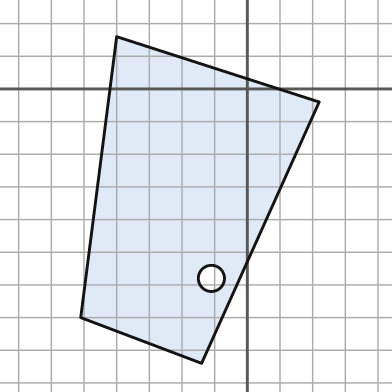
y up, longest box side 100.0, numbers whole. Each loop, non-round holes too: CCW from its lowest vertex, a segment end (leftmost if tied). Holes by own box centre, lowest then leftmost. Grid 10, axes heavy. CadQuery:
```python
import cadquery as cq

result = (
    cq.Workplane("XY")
    .moveTo(-14.0, -84.0)
    .lineTo(22.0, -4.0)
    .lineTo(-40.0, 16.0)
    .lineTo(-51.0, -70.0)
    .close()
    .moveTo(-11.0, -58.0)
    .circle(4.0)
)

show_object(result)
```